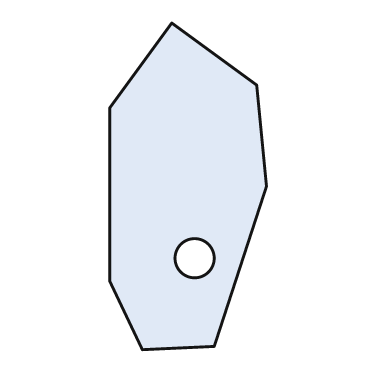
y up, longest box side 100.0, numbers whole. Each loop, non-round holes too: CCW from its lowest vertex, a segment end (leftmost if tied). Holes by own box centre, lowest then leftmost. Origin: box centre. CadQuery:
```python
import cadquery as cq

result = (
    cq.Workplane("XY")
    .moveTo(-14.0, -50.0)
    .lineTo(8.0, -49.0)
    .lineTo(24.0, 0.0)
    .lineTo(21.0, 31.0)
    .lineTo(-5.0, 50.0)
    .lineTo(-24.0, 24.0)
    .lineTo(-24.0, -29.0)
    .close()
    .moveTo(2.0, -22.0)
    .circle(6.0)
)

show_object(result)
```